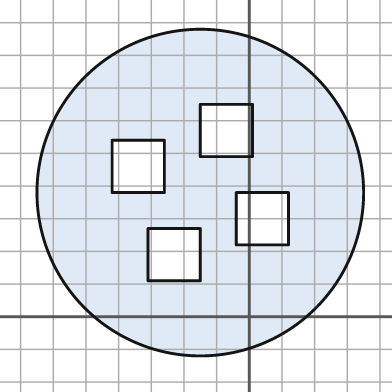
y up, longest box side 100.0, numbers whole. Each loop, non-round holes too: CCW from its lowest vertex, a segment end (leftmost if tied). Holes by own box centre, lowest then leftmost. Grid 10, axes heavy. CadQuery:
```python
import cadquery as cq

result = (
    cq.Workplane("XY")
    .moveTo(-15.0, 38.0)
    .circle(50.0)
    .moveTo(-31.0, 11.0)
    .lineTo(-15.0, 11.0)
    .lineTo(-15.0, 27.0)
    .lineTo(-31.0, 27.0)
    .close()
    .moveTo(-4.0, 22.0)
    .lineTo(12.0, 22.0)
    .lineTo(12.0, 38.0)
    .lineTo(-4.0, 38.0)
    .close()
    .moveTo(-42.0, 38.0)
    .lineTo(-26.0, 38.0)
    .lineTo(-26.0, 54.0)
    .lineTo(-42.0, 54.0)
    .close()
    .moveTo(-15.0, 49.0)
    .lineTo(1.0, 49.0)
    .lineTo(1.0, 65.0)
    .lineTo(-15.0, 65.0)
    .close()
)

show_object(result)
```